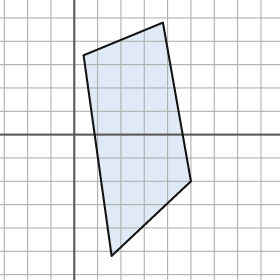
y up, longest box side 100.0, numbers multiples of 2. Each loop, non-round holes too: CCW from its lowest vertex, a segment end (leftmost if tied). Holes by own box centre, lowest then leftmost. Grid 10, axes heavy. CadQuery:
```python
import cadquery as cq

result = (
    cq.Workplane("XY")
    .moveTo(16.0, -52.0)
    .lineTo(50.0, -20.0)
    .lineTo(38.0, 48.0)
    .lineTo(4.0, 34.0)
    .close()
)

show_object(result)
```